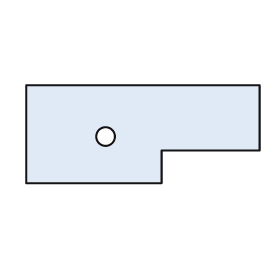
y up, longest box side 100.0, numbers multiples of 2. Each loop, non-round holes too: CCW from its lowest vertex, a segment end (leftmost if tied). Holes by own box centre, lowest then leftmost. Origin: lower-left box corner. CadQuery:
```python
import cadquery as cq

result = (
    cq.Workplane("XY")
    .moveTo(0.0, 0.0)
    .lineTo(58.0, 0.0)
    .lineTo(58.0, 14.0)
    .lineTo(100.0, 14.0)
    .lineTo(100.0, 42.0)
    .lineTo(0.0, 42.0)
    .close()
    .moveTo(34.0, 20.0)
    .circle(4.0)
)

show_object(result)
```